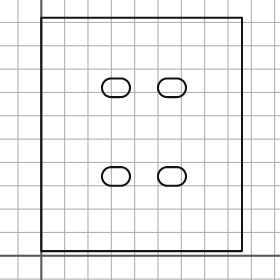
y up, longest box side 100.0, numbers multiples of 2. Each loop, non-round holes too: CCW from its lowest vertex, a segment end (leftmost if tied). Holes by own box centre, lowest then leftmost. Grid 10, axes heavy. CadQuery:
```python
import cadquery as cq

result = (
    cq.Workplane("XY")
    .moveTo(0.0, 2.0)
    .lineTo(86.0, 2.0)
    .lineTo(86.0, 102.0)
    .lineTo(0.0, 102.0)
    .close()
    .moveTo(30.0, 30.0)
    .lineTo(34.0, 30.0)
    .threePointArc((38.0, 34.0), (34.0, 38.0))
    .lineTo(30.0, 38.0)
    .threePointArc((26.0, 34.0), (30.0, 30.0))
    .close()
    .moveTo(54.0, 30.0)
    .lineTo(58.0, 30.0)
    .threePointArc((62.0, 34.0), (58.0, 38.0))
    .lineTo(54.0, 38.0)
    .threePointArc((50.0, 34.0), (54.0, 30.0))
    .close()
    .moveTo(30.0, 68.0)
    .lineTo(34.0, 68.0)
    .threePointArc((38.0, 72.0), (34.0, 76.0))
    .lineTo(30.0, 76.0)
    .threePointArc((26.0, 72.0), (30.0, 68.0))
    .close()
    .moveTo(54.0, 68.0)
    .lineTo(58.0, 68.0)
    .threePointArc((62.0, 72.0), (58.0, 76.0))
    .lineTo(54.0, 76.0)
    .threePointArc((50.0, 72.0), (54.0, 68.0))
    .close()
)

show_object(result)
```